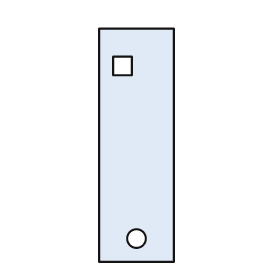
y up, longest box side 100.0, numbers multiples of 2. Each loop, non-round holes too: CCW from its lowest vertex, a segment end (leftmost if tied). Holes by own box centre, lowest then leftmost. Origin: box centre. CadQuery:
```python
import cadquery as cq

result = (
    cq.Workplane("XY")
    .moveTo(-16.0, -50.0)
    .lineTo(16.0, -50.0)
    .lineTo(16.0, 50.0)
    .lineTo(-16.0, 50.0)
    .close()
    .moveTo(0.0, -40.0)
    .circle(4.0)
    .moveTo(-10.0, 30.0)
    .lineTo(-2.0, 30.0)
    .lineTo(-2.0, 38.0)
    .lineTo(-10.0, 38.0)
    .close()
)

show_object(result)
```